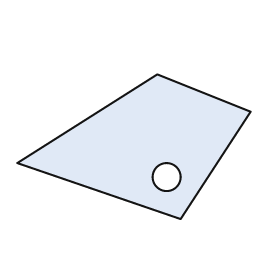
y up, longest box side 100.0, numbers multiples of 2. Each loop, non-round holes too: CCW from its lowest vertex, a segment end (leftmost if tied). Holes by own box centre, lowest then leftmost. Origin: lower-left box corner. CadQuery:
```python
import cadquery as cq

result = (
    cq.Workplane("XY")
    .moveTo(70.0, 0.0)
    .lineTo(100.0, 46.0)
    .lineTo(60.0, 62.0)
    .lineTo(0.0, 24.0)
    .close()
    .moveTo(64.0, 18.0)
    .circle(6.0)
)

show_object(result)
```